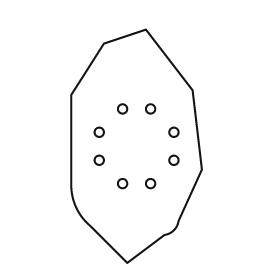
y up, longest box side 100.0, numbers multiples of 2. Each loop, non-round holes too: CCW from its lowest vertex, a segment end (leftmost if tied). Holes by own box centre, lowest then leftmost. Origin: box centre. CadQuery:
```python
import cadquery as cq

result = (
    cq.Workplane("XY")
    .moveTo(-4.0, -50.0)
    .lineTo(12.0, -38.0)
    .threePointArc((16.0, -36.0), (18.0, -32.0))
    .lineTo(28.0, -10.0)
    .lineTo(24.0, 24.0)
    .lineTo(4.0, 50.0)
    .lineTo(-14.0, 44.0)
    .lineTo(-28.0, 22.0)
    .lineTo(-28.0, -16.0)
    .threePointArc((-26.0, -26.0), (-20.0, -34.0))
    .close()
    .moveTo(-6.0, -16.0)
    .circle(2.0)
    .moveTo(6.0, -16.0)
    .circle(2.0)
    .moveTo(-16.0, -6.0)
    .circle(2.0)
    .moveTo(16.0, -6.0)
    .circle(2.0)
    .moveTo(-16.0, 6.0)
    .circle(2.0)
    .moveTo(16.0, 6.0)
    .circle(2.0)
    .moveTo(-6.0, 16.0)
    .circle(2.0)
    .moveTo(6.0, 16.0)
    .circle(2.0)
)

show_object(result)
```